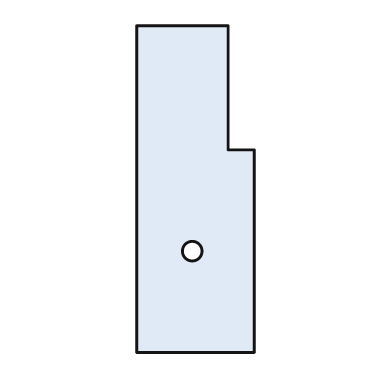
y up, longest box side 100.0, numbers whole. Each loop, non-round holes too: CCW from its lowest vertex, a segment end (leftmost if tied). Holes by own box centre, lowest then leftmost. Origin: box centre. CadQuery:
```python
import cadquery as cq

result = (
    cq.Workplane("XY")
    .moveTo(-18.0, -50.0)
    .lineTo(18.0, -50.0)
    .lineTo(18.0, 12.0)
    .lineTo(10.0, 12.0)
    .lineTo(10.0, 50.0)
    .lineTo(-18.0, 50.0)
    .close()
    .moveTo(-1.0, -19.0)
    .circle(3.0)
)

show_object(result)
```